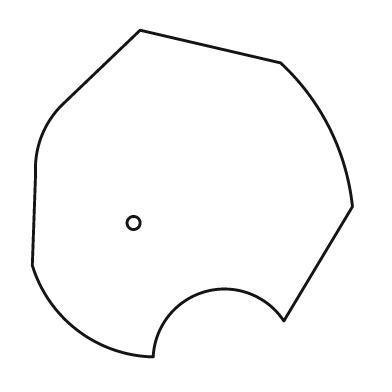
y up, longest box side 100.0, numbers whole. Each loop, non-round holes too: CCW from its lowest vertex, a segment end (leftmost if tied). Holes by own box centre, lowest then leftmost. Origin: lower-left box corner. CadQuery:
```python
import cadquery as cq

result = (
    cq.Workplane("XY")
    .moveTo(37.0, 0.0)
    .threePointArc((53.0, 20.0), (77.0, 11.0))
    .lineTo(98.0, 46.0)
    .threePointArc((91.0, 70.0), (76.0, 90.0))
    .lineTo(33.0, 100.0)
    .lineTo(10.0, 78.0)
    .threePointArc((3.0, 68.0), (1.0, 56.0))
    .lineTo(0.0, 28.0)
    .threePointArc((14.0, 8.0), (37.0, 0.0))
    .close()
    .moveTo(31.0, 41.0)
    .circle(2.0)
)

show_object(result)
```